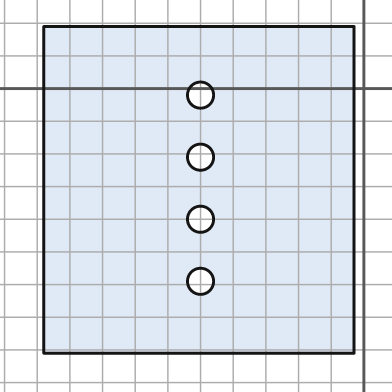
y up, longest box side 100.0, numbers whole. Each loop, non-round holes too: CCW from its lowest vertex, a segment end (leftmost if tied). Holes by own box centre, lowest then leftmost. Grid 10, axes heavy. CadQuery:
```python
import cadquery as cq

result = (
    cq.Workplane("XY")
    .moveTo(-98.0, -81.0)
    .lineTo(-3.0, -81.0)
    .lineTo(-3.0, 19.0)
    .lineTo(-98.0, 19.0)
    .close()
    .moveTo(-50.0, -59.0)
    .circle(4.0)
    .moveTo(-50.0, -40.0)
    .circle(4.0)
    .moveTo(-50.0, -21.0)
    .circle(4.0)
    .moveTo(-50.0, -2.0)
    .circle(4.0)
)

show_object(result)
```